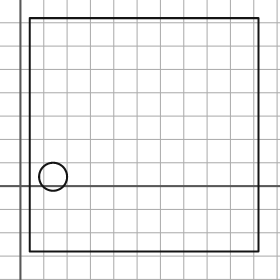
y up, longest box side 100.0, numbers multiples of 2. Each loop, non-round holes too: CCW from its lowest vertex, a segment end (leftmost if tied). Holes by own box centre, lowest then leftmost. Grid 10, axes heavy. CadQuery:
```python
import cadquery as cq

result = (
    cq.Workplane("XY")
    .moveTo(4.0, -28.0)
    .lineTo(102.0, -28.0)
    .lineTo(102.0, 72.0)
    .lineTo(4.0, 72.0)
    .close()
    .moveTo(14.0, 4.0)
    .circle(6.0)
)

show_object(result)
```